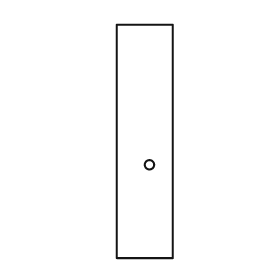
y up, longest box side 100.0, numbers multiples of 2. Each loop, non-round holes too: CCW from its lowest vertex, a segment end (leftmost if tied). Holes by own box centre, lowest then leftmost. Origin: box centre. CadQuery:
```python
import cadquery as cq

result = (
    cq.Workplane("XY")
    .moveTo(-12.0, -50.0)
    .lineTo(12.0, -50.0)
    .lineTo(12.0, 50.0)
    .lineTo(-12.0, 50.0)
    .close()
    .moveTo(2.0, -10.0)
    .circle(2.0)
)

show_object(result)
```